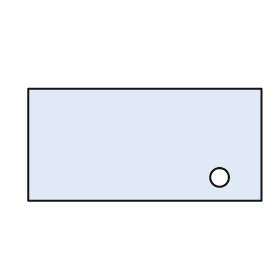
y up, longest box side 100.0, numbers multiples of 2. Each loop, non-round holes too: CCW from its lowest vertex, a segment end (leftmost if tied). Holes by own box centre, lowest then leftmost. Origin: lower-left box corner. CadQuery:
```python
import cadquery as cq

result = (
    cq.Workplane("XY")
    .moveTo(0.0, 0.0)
    .lineTo(100.0, 0.0)
    .lineTo(100.0, 48.0)
    .lineTo(0.0, 48.0)
    .close()
    .moveTo(82.0, 10.0)
    .circle(4.0)
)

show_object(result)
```